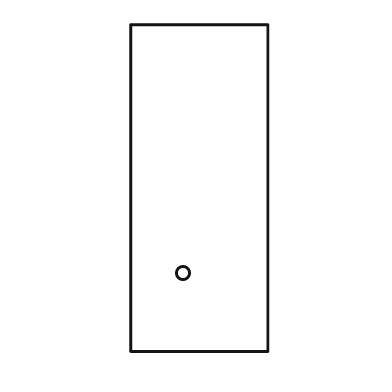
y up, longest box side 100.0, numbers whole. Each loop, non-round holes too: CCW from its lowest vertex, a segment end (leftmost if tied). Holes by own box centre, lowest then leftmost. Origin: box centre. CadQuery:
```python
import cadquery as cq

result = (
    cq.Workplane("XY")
    .moveTo(-21.0, -50.0)
    .lineTo(21.0, -50.0)
    .lineTo(21.0, 50.0)
    .lineTo(-21.0, 50.0)
    .close()
    .moveTo(-5.0, -26.0)
    .circle(2.0)
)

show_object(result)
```